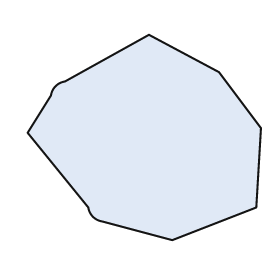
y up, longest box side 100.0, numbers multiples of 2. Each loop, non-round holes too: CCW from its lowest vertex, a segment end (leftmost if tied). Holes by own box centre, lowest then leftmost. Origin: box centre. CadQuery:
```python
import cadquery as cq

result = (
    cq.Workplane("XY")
    .moveTo(12.0, -44.0)
    .lineTo(48.0, -30.0)
    .lineTo(50.0, 4.0)
    .lineTo(32.0, 28.0)
    .lineTo(2.0, 44.0)
    .lineTo(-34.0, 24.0)
    .threePointArc((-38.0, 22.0), (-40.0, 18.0))
    .lineTo(-50.0, 2.0)
    .lineTo(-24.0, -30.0)
    .threePointArc((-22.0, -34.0), (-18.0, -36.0))
    .close()
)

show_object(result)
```